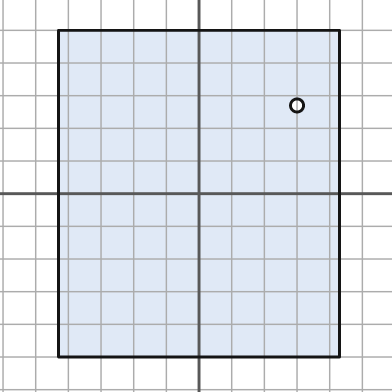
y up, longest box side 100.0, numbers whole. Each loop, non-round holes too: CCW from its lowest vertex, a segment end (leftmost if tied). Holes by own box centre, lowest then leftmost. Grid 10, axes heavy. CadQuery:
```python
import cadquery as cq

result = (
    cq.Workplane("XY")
    .moveTo(-43.0, -50.0)
    .lineTo(43.0, -50.0)
    .lineTo(43.0, 50.0)
    .lineTo(-43.0, 50.0)
    .close()
    .moveTo(30.0, 27.0)
    .circle(2.0)
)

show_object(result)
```